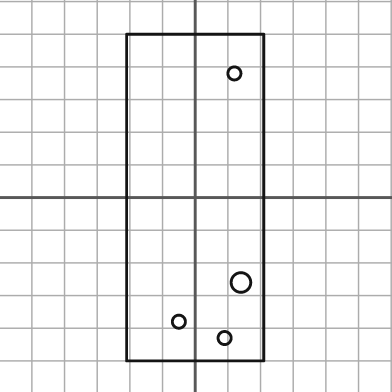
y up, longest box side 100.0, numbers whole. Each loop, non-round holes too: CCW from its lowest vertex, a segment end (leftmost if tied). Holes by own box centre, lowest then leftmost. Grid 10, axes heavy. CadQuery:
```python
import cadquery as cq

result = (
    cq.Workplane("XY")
    .moveTo(-21.0, -50.0)
    .lineTo(21.0, -50.0)
    .lineTo(21.0, 50.0)
    .lineTo(-21.0, 50.0)
    .close()
    .moveTo(9.0, -43.0)
    .circle(2.0)
    .moveTo(-5.0, -38.0)
    .circle(2.0)
    .moveTo(14.0, -26.0)
    .circle(3.0)
    .moveTo(12.0, 38.0)
    .circle(2.0)
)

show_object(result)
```